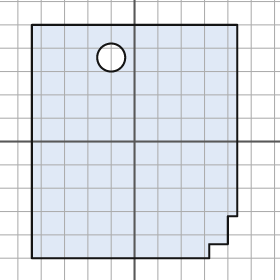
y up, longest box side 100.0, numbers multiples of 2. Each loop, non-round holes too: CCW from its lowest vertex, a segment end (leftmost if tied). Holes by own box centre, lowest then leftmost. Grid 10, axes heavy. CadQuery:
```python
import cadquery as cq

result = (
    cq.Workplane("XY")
    .moveTo(-44.0, -50.0)
    .lineTo(32.0, -50.0)
    .lineTo(32.0, -44.0)
    .lineTo(40.0, -44.0)
    .lineTo(40.0, -32.0)
    .lineTo(44.0, -32.0)
    .lineTo(44.0, 50.0)
    .lineTo(-44.0, 50.0)
    .close()
    .moveTo(-10.0, 36.0)
    .circle(6.0)
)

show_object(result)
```